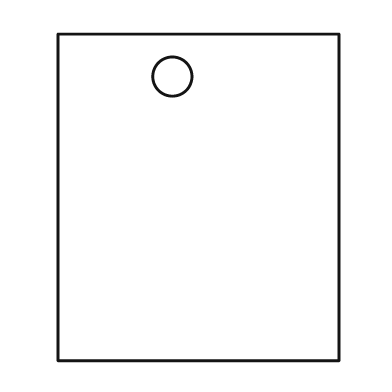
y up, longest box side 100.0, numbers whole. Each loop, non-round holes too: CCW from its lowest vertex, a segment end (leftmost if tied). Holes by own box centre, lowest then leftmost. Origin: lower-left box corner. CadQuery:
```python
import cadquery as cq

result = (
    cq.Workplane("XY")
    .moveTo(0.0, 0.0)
    .lineTo(86.0, 0.0)
    .lineTo(86.0, 100.0)
    .lineTo(0.0, 100.0)
    .close()
    .moveTo(35.0, 87.0)
    .circle(6.0)
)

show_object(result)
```